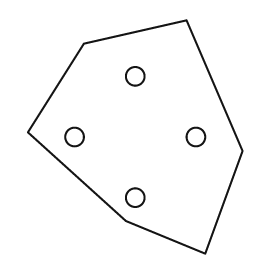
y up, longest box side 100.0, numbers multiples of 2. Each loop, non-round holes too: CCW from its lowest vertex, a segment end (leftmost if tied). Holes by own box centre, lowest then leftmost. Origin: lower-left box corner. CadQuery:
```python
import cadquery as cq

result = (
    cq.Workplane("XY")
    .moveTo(76.0, 0.0)
    .lineTo(92.0, 44.0)
    .lineTo(68.0, 100.0)
    .lineTo(24.0, 90.0)
    .lineTo(0.0, 52.0)
    .lineTo(42.0, 14.0)
    .close()
    .moveTo(46.0, 24.0)
    .circle(4.0)
    .moveTo(20.0, 50.0)
    .circle(4.0)
    .moveTo(72.0, 50.0)
    .circle(4.0)
    .moveTo(46.0, 76.0)
    .circle(4.0)
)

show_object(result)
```